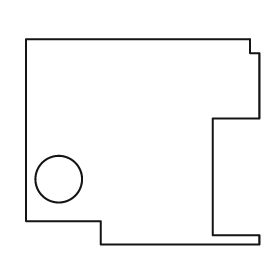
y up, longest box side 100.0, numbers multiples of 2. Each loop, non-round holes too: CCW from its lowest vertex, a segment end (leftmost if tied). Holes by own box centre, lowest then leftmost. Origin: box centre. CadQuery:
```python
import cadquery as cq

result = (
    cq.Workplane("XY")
    .moveTo(-18.0, -44.0)
    .lineTo(50.0, -44.0)
    .lineTo(50.0, -40.0)
    .lineTo(30.0, -40.0)
    .lineTo(30.0, 10.0)
    .lineTo(50.0, 10.0)
    .lineTo(50.0, 38.0)
    .lineTo(46.0, 38.0)
    .lineTo(46.0, 44.0)
    .lineTo(-50.0, 44.0)
    .lineTo(-50.0, -34.0)
    .lineTo(-18.0, -34.0)
    .close()
    .moveTo(-36.0, -16.0)
    .circle(10.0)
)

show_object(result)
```